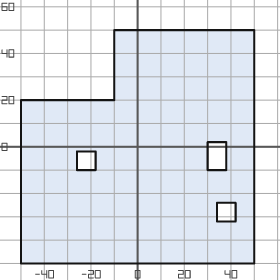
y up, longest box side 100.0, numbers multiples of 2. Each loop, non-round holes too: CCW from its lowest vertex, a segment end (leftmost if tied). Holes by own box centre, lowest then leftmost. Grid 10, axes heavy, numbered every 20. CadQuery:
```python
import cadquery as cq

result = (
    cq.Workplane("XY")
    .moveTo(-50.0, -50.0)
    .lineTo(50.0, -50.0)
    .lineTo(50.0, 50.0)
    .lineTo(-10.0, 50.0)
    .lineTo(-10.0, 20.0)
    .lineTo(-50.0, 20.0)
    .close()
    .moveTo(34.0, -32.0)
    .lineTo(42.0, -32.0)
    .lineTo(42.0, -24.0)
    .lineTo(34.0, -24.0)
    .close()
    .moveTo(-26.0, -10.0)
    .lineTo(-18.0, -10.0)
    .lineTo(-18.0, -2.0)
    .lineTo(-26.0, -2.0)
    .close()
    .moveTo(30.0, -10.0)
    .lineTo(38.0, -10.0)
    .lineTo(38.0, 2.0)
    .lineTo(30.0, 2.0)
    .close()
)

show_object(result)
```